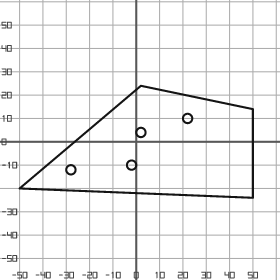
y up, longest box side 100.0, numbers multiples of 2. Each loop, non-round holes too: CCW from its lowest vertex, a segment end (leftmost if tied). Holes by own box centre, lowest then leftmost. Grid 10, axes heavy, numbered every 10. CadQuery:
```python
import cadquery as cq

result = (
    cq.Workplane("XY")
    .moveTo(50.0, -24.0)
    .lineTo(50.0, 14.0)
    .lineTo(2.0, 24.0)
    .lineTo(-50.0, -20.0)
    .close()
    .moveTo(-28.0, -12.0)
    .circle(2.0)
    .moveTo(-2.0, -10.0)
    .circle(2.0)
    .moveTo(2.0, 4.0)
    .circle(2.0)
    .moveTo(22.0, 10.0)
    .circle(2.0)
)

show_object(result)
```